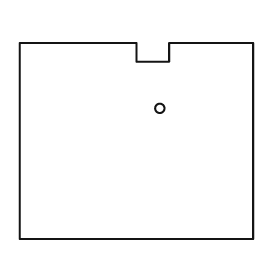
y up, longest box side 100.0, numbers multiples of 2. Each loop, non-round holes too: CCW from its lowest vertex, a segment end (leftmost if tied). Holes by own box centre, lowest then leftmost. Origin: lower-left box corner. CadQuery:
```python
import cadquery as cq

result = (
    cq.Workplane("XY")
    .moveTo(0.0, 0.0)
    .lineTo(100.0, 0.0)
    .lineTo(100.0, 84.0)
    .lineTo(64.0, 84.0)
    .lineTo(64.0, 76.0)
    .lineTo(50.0, 76.0)
    .lineTo(50.0, 84.0)
    .lineTo(0.0, 84.0)
    .close()
    .moveTo(60.0, 56.0)
    .circle(2.0)
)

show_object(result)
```